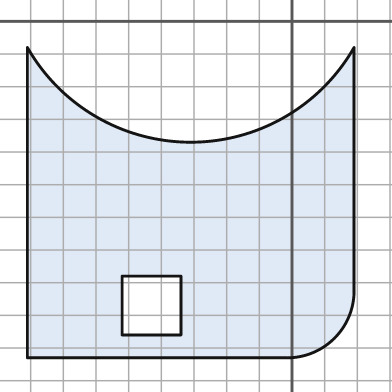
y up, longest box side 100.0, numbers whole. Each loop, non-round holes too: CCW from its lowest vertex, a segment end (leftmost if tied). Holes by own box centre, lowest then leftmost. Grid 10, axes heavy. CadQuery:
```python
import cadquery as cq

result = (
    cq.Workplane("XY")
    .moveTo(-81.0, -103.0)
    .lineTo(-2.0, -103.0)
    .threePointArc((13.0, -97.0), (19.0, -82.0))
    .lineTo(19.0, -8.0)
    .threePointArc((-31.0, -37.0), (-81.0, -8.0))
    .close()
    .moveTo(-52.0, -96.0)
    .lineTo(-34.0, -96.0)
    .lineTo(-34.0, -78.0)
    .lineTo(-52.0, -78.0)
    .close()
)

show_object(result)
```